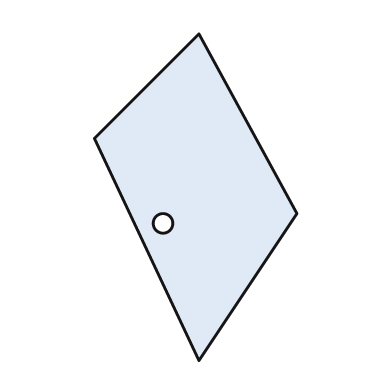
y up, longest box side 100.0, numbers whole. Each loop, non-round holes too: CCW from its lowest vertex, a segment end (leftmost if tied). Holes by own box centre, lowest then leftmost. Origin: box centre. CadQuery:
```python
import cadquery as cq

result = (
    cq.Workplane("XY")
    .moveTo(1.0, -50.0)
    .lineTo(31.0, -5.0)
    .lineTo(1.0, 50.0)
    .lineTo(-31.0, 18.0)
    .close()
    .moveTo(-10.0, -8.0)
    .circle(3.0)
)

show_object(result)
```